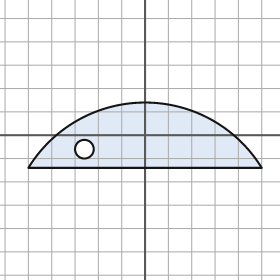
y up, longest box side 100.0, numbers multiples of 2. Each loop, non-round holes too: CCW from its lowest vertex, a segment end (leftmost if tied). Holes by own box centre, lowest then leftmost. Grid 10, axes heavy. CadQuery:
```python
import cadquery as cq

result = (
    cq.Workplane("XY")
    .moveTo(-50.0, -14.0)
    .lineTo(50.0, -14.0)
    .threePointArc((0.0, 14.0), (-50.0, -14.0))
    .close()
    .moveTo(-26.0, -6.0)
    .circle(4.0)
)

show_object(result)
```